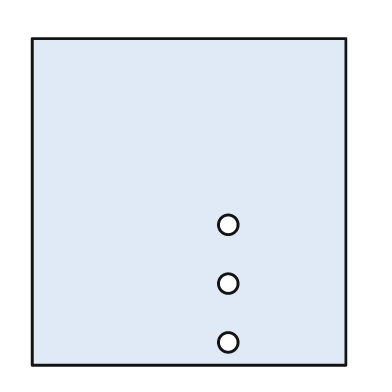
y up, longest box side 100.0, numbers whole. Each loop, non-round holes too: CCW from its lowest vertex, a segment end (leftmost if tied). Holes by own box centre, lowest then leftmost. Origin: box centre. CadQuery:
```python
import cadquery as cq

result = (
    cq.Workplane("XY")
    .moveTo(-48.0, -50.0)
    .lineTo(48.0, -50.0)
    .lineTo(48.0, 50.0)
    .lineTo(-48.0, 50.0)
    .close()
    .moveTo(12.0, -43.0)
    .circle(3.0)
    .moveTo(12.0, -25.0)
    .circle(3.0)
    .moveTo(12.0, -7.0)
    .circle(3.0)
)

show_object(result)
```